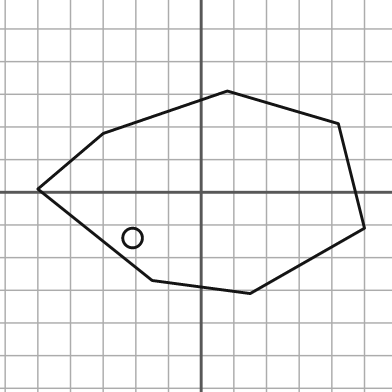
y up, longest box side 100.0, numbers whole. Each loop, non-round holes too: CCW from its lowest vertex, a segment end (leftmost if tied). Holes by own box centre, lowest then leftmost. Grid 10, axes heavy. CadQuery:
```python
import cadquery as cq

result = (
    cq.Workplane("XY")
    .moveTo(15.0, -31.0)
    .lineTo(50.0, -11.0)
    .lineTo(42.0, 21.0)
    .lineTo(8.0, 31.0)
    .lineTo(-30.0, 18.0)
    .lineTo(-50.0, 1.0)
    .lineTo(-15.0, -27.0)
    .close()
    .moveTo(-21.0, -14.0)
    .circle(3.0)
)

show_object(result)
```